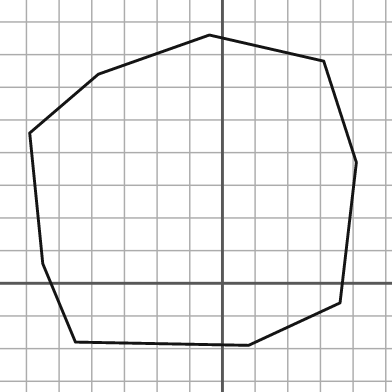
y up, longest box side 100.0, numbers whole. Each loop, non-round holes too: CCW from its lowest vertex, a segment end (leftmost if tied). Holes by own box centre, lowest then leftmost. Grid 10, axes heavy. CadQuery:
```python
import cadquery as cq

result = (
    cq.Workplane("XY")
    .moveTo(8.0, -19.0)
    .lineTo(36.0, -6.0)
    .lineTo(41.0, 37.0)
    .lineTo(31.0, 68.0)
    .lineTo(-4.0, 76.0)
    .lineTo(-38.0, 64.0)
    .lineTo(-59.0, 46.0)
    .lineTo(-55.0, 6.0)
    .lineTo(-45.0, -18.0)
    .close()
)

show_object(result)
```